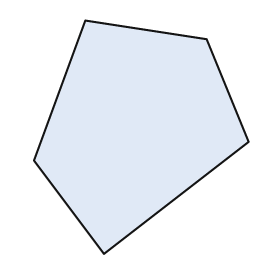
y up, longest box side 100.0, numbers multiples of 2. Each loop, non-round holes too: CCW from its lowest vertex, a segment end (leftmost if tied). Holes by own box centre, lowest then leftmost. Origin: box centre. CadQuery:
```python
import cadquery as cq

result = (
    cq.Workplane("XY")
    .moveTo(-16.0, -50.0)
    .lineTo(46.0, -2.0)
    .lineTo(28.0, 42.0)
    .lineTo(-24.0, 50.0)
    .lineTo(-46.0, -10.0)
    .close()
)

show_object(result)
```